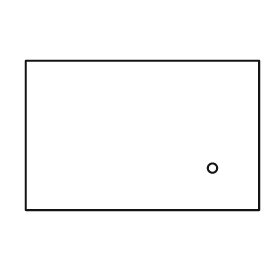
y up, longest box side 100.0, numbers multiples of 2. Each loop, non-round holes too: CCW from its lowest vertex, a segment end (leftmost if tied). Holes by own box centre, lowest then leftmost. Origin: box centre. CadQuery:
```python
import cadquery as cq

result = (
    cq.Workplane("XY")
    .moveTo(-50.0, -32.0)
    .lineTo(50.0, -32.0)
    .lineTo(50.0, 32.0)
    .lineTo(-50.0, 32.0)
    .close()
    .moveTo(30.0, -14.0)
    .circle(2.0)
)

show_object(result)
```